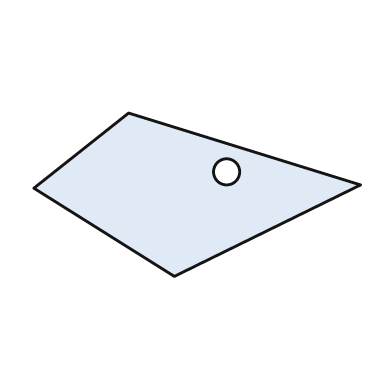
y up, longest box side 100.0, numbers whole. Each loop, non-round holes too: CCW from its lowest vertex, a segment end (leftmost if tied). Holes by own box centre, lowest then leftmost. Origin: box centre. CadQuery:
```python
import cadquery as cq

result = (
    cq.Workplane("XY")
    .moveTo(-7.0, -25.0)
    .lineTo(50.0, 3.0)
    .lineTo(-21.0, 25.0)
    .lineTo(-50.0, 2.0)
    .close()
    .moveTo(9.0, 7.0)
    .circle(4.0)
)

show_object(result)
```